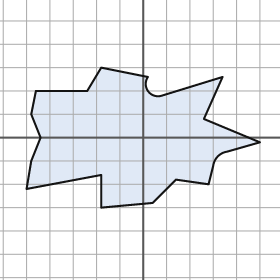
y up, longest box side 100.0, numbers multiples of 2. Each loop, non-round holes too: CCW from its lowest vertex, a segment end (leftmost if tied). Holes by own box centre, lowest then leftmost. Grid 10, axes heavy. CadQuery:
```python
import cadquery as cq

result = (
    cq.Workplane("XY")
    .moveTo(-18.0, -30.0)
    .lineTo(4.0, -28.0)
    .lineTo(14.0, -18.0)
    .lineTo(28.0, -20.0)
    .lineTo(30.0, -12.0)
    .threePointArc((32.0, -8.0), (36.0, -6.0))
    .lineTo(50.0, -2.0)
    .lineTo(26.0, 8.0)
    .lineTo(34.0, 26.0)
    .lineTo(8.0, 18.0)
    .threePointArc((2.0, 20.0), (2.0, 26.0))
    .lineTo(-18.0, 30.0)
    .lineTo(-24.0, 20.0)
    .lineTo(-46.0, 20.0)
    .lineTo(-48.0, 10.0)
    .lineTo(-44.0, 0.0)
    .lineTo(-48.0, -10.0)
    .lineTo(-50.0, -22.0)
    .lineTo(-18.0, -16.0)
    .close()
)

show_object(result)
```